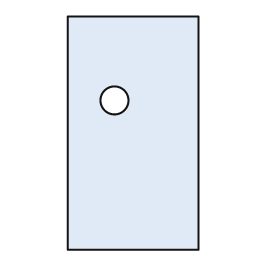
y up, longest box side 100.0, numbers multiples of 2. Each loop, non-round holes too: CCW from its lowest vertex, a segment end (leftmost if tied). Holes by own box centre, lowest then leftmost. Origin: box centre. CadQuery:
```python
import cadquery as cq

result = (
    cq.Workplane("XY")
    .moveTo(-28.0, -50.0)
    .lineTo(28.0, -50.0)
    .lineTo(28.0, 50.0)
    .lineTo(-28.0, 50.0)
    .close()
    .moveTo(-8.0, 14.0)
    .circle(6.0)
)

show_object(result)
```